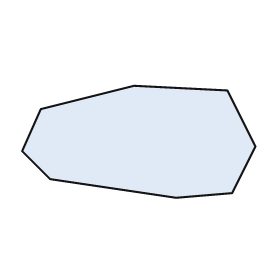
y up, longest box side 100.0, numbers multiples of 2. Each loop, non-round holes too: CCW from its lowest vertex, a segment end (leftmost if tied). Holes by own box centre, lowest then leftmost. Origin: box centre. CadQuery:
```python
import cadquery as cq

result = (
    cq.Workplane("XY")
    .moveTo(16.0, -24.0)
    .lineTo(40.0, -22.0)
    .lineTo(50.0, -2.0)
    .lineTo(38.0, 22.0)
    .lineTo(-2.0, 24.0)
    .lineTo(-42.0, 14.0)
    .lineTo(-50.0, -4.0)
    .lineTo(-38.0, -16.0)
    .close()
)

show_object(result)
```